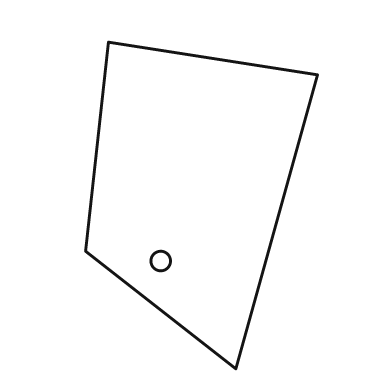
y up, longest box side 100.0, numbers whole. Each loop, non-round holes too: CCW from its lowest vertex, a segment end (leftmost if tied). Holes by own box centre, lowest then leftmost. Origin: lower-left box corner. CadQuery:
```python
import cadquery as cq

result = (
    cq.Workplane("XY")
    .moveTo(46.0, 0.0)
    .lineTo(71.0, 90.0)
    .lineTo(7.0, 100.0)
    .lineTo(0.0, 36.0)
    .close()
    .moveTo(23.0, 33.0)
    .circle(3.0)
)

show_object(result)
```